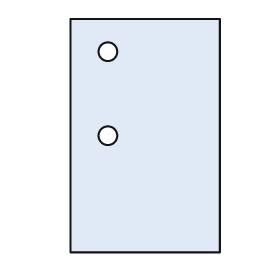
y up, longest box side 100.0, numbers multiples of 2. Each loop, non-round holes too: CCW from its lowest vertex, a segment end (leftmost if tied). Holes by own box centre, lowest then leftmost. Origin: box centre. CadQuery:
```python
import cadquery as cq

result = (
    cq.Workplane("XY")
    .moveTo(-32.0, -50.0)
    .lineTo(32.0, -50.0)
    .lineTo(32.0, 50.0)
    .lineTo(-32.0, 50.0)
    .close()
    .moveTo(-16.0, 0.0)
    .circle(4.0)
    .moveTo(-16.0, 36.0)
    .circle(4.0)
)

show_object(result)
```